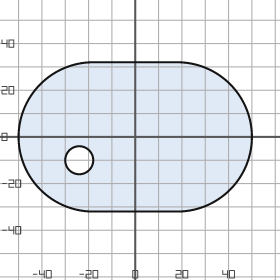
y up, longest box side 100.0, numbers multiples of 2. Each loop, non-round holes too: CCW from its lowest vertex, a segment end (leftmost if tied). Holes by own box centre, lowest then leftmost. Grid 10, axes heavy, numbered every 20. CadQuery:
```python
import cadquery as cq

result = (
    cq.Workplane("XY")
    .moveTo(-18.0, -32.0)
    .lineTo(18.0, -32.0)
    .threePointArc((50.0, 0.0), (18.0, 32.0))
    .lineTo(-18.0, 32.0)
    .threePointArc((-50.0, 0.0), (-18.0, -32.0))
    .close()
    .moveTo(-24.0, -10.0)
    .circle(6.0)
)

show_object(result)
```